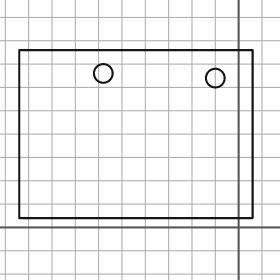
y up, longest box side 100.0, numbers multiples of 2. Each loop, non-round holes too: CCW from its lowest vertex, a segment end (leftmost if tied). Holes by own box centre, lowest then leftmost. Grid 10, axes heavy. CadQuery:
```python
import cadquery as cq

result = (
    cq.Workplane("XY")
    .moveTo(-94.0, 4.0)
    .lineTo(6.0, 4.0)
    .lineTo(6.0, 76.0)
    .lineTo(-94.0, 76.0)
    .close()
    .moveTo(-10.0, 64.0)
    .circle(4.0)
    .moveTo(-58.0, 66.0)
    .circle(4.0)
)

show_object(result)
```